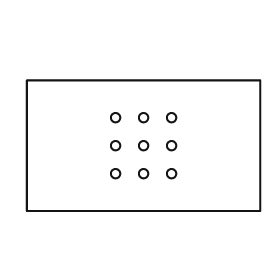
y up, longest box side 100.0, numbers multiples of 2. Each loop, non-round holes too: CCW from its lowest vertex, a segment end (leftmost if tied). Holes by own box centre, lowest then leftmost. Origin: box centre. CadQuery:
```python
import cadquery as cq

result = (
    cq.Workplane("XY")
    .moveTo(-50.0, -28.0)
    .lineTo(50.0, -28.0)
    .lineTo(50.0, 28.0)
    .lineTo(-50.0, 28.0)
    .close()
    .moveTo(-12.0, -12.0)
    .circle(2.0)
    .moveTo(0.0, -12.0)
    .circle(2.0)
    .moveTo(12.0, -12.0)
    .circle(2.0)
    .moveTo(-12.0, 0.0)
    .circle(2.0)
    .moveTo(0.0, 0.0)
    .circle(2.0)
    .moveTo(12.0, 0.0)
    .circle(2.0)
    .moveTo(-12.0, 12.0)
    .circle(2.0)
    .moveTo(0.0, 12.0)
    .circle(2.0)
    .moveTo(12.0, 12.0)
    .circle(2.0)
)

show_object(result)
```